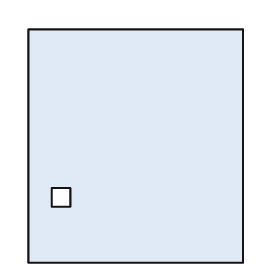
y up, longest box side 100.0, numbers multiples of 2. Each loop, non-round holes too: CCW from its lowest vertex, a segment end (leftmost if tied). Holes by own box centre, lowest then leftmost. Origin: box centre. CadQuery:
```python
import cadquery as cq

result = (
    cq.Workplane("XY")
    .moveTo(-46.0, -50.0)
    .lineTo(46.0, -50.0)
    .lineTo(46.0, 50.0)
    .lineTo(-46.0, 50.0)
    .close()
    .moveTo(-36.0, -26.0)
    .lineTo(-28.0, -26.0)
    .lineTo(-28.0, -18.0)
    .lineTo(-36.0, -18.0)
    .close()
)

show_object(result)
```